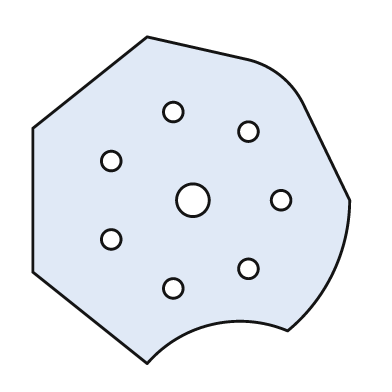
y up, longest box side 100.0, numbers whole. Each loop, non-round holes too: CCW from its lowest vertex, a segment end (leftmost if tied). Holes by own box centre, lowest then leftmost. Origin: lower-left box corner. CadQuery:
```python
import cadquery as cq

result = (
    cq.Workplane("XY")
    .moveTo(35.0, 0.0)
    .threePointArc((55.0, 12.0), (78.0, 10.0))
    .threePointArc((92.0, 28.0), (97.0, 50.0))
    .lineTo(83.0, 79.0)
    .threePointArc((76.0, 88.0), (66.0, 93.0))
    .lineTo(35.0, 100.0)
    .lineTo(0.0, 72.0)
    .lineTo(0.0, 28.0)
    .close()
    .moveTo(43.0, 23.0)
    .circle(3.0)
    .moveTo(66.0, 29.0)
    .circle(3.0)
    .moveTo(24.0, 38.0)
    .circle(3.0)
    .moveTo(49.0, 50.0)
    .circle(5.0)
    .moveTo(76.0, 50.0)
    .circle(3.0)
    .moveTo(24.0, 62.0)
    .circle(3.0)
    .moveTo(66.0, 71.0)
    .circle(3.0)
    .moveTo(43.0, 77.0)
    .circle(3.0)
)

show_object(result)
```